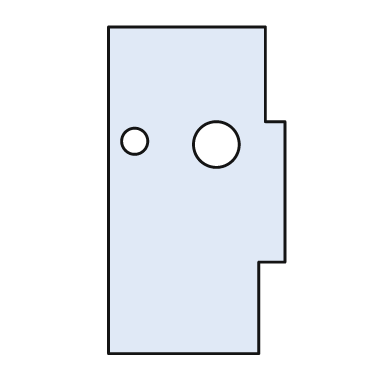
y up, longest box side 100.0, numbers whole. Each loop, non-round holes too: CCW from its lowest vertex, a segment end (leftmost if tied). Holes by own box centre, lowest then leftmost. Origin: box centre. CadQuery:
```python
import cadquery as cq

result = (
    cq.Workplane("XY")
    .moveTo(-27.0, -50.0)
    .lineTo(19.0, -50.0)
    .lineTo(19.0, -22.0)
    .lineTo(27.0, -22.0)
    .lineTo(27.0, 21.0)
    .lineTo(21.0, 21.0)
    .lineTo(21.0, 50.0)
    .lineTo(-27.0, 50.0)
    .close()
    .moveTo(6.0, 14.0)
    .circle(7.0)
    .moveTo(-19.0, 15.0)
    .circle(4.0)
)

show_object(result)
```